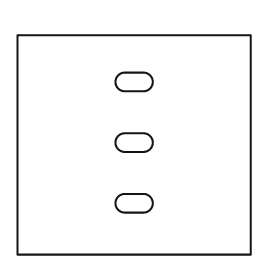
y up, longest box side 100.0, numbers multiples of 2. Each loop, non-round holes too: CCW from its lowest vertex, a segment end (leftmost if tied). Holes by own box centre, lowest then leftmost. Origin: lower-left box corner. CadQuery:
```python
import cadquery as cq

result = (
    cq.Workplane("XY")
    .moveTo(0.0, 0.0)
    .lineTo(100.0, 0.0)
    .lineTo(100.0, 94.0)
    .lineTo(0.0, 94.0)
    .close()
    .moveTo(46.0, 18.0)
    .lineTo(54.0, 18.0)
    .threePointArc((58.0, 22.0), (54.0, 26.0))
    .lineTo(46.0, 26.0)
    .threePointArc((42.0, 22.0), (46.0, 18.0))
    .close()
    .moveTo(46.0, 44.0)
    .lineTo(54.0, 44.0)
    .threePointArc((58.0, 48.0), (54.0, 52.0))
    .lineTo(46.0, 52.0)
    .threePointArc((42.0, 48.0), (46.0, 44.0))
    .close()
    .moveTo(46.0, 70.0)
    .lineTo(54.0, 70.0)
    .threePointArc((58.0, 74.0), (54.0, 78.0))
    .lineTo(46.0, 78.0)
    .threePointArc((42.0, 74.0), (46.0, 70.0))
    .close()
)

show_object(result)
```